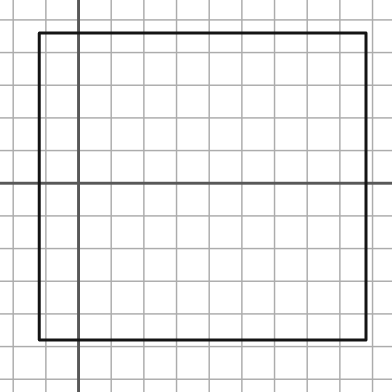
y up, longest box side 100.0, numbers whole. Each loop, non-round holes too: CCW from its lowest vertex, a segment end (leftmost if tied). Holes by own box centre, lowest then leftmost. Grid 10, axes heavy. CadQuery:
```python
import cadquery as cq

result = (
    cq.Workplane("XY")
    .moveTo(-12.0, -48.0)
    .lineTo(88.0, -48.0)
    .lineTo(88.0, 46.0)
    .lineTo(-12.0, 46.0)
    .close()
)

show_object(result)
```